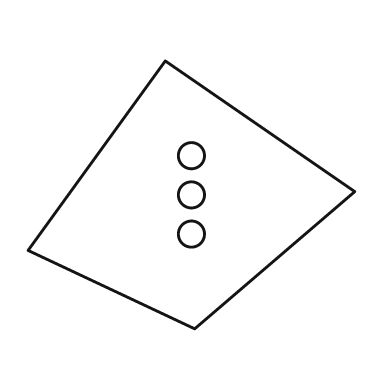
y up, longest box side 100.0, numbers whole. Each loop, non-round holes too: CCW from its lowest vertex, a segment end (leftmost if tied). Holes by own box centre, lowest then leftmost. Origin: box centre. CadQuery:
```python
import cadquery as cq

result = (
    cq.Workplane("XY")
    .moveTo(1.0, -41.0)
    .lineTo(50.0, 1.0)
    .lineTo(-8.0, 41.0)
    .lineTo(-50.0, -17.0)
    .close()
    .moveTo(0.0, -12.0)
    .circle(4.0)
    .moveTo(0.0, 0.0)
    .circle(4.0)
    .moveTo(0.0, 12.0)
    .circle(4.0)
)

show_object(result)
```